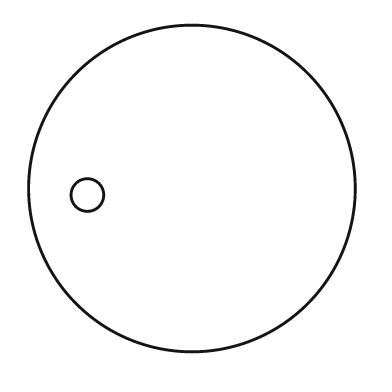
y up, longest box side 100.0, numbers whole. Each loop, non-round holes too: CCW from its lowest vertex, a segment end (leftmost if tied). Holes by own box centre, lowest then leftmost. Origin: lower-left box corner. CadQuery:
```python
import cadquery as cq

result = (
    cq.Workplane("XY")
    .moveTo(50.0, 50.0)
    .circle(50.0)
    .moveTo(18.0, 48.0)
    .circle(5.0)
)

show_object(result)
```